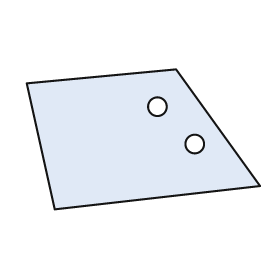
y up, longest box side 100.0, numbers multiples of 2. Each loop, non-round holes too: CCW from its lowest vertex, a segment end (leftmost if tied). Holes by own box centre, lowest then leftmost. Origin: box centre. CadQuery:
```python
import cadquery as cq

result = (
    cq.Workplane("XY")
    .moveTo(-38.0, -30.0)
    .lineTo(50.0, -20.0)
    .lineTo(14.0, 30.0)
    .lineTo(-50.0, 24.0)
    .close()
    .moveTo(22.0, -2.0)
    .circle(4.0)
    .moveTo(6.0, 14.0)
    .circle(4.0)
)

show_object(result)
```